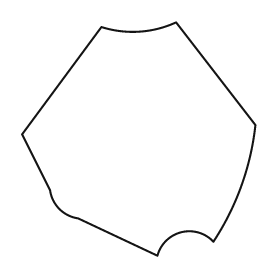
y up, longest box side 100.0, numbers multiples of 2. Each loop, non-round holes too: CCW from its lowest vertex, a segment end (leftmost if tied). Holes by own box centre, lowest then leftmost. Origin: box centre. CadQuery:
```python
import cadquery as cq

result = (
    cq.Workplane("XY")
    .moveTo(8.0, -50.0)
    .threePointArc((18.0, -40.0), (32.0, -44.0))
    .threePointArc((44.0, -20.0), (50.0, 6.0))
    .lineTo(16.0, 50.0)
    .threePointArc((0.0, 46.0), (-16.0, 48.0))
    .lineTo(-50.0, 2.0)
    .lineTo(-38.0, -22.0)
    .threePointArc((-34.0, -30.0), (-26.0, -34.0))
    .close()
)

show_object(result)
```